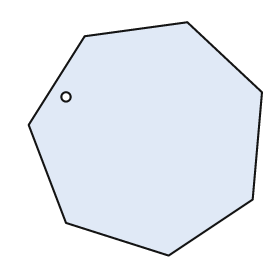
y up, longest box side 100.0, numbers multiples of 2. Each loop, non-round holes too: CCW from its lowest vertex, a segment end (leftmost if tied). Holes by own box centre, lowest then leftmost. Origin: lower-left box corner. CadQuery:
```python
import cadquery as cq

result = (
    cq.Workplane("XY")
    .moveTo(60.0, 0.0)
    .lineTo(96.0, 24.0)
    .lineTo(100.0, 70.0)
    .lineTo(68.0, 100.0)
    .lineTo(24.0, 94.0)
    .lineTo(0.0, 56.0)
    .lineTo(16.0, 14.0)
    .close()
    .moveTo(16.0, 68.0)
    .circle(2.0)
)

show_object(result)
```